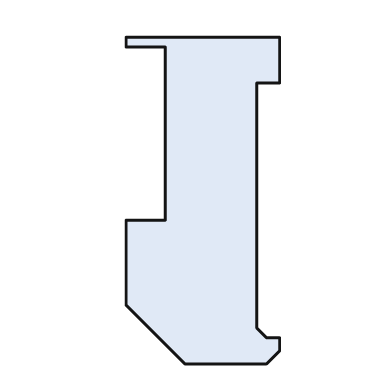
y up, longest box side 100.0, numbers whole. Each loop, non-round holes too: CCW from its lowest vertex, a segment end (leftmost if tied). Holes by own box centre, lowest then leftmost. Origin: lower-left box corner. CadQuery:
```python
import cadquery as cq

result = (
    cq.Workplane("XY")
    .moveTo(18.0, 0.0)
    .lineTo(43.0, 0.0)
    .lineTo(47.0, 4.0)
    .lineTo(47.0, 8.0)
    .lineTo(43.0, 8.0)
    .lineTo(40.0, 11.0)
    .lineTo(40.0, 86.0)
    .lineTo(47.0, 86.0)
    .lineTo(47.0, 100.0)
    .lineTo(0.0, 100.0)
    .lineTo(0.0, 97.0)
    .lineTo(12.0, 97.0)
    .lineTo(12.0, 44.0)
    .lineTo(0.0, 44.0)
    .lineTo(0.0, 18.0)
    .close()
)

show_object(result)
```